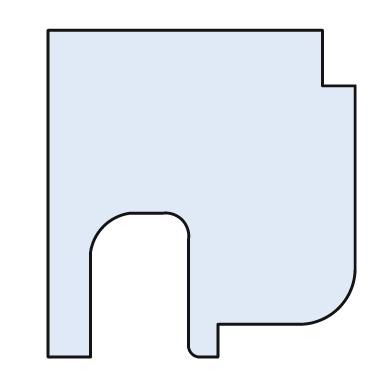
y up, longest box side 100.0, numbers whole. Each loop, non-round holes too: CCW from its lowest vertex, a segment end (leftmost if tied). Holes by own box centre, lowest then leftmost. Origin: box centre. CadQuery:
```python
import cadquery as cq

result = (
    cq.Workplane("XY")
    .moveTo(-47.0, -50.0)
    .lineTo(-34.0, -50.0)
    .lineTo(-34.0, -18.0)
    .threePointArc((-30.0, -10.0), (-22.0, -6.0))
    .lineTo(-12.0, -6.0)
    .threePointArc((-6.0, -8.0), (-4.0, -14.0))
    .lineTo(-4.0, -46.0)
    .threePointArc((-3.0, -49.0), (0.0, -50.0))
    .lineTo(5.0, -50.0)
    .lineTo(5.0, -40.0)
    .lineTo(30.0, -40.0)
    .threePointArc((42.0, -35.0), (47.0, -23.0))
    .lineTo(47.0, 33.0)
    .lineTo(37.0, 33.0)
    .lineTo(37.0, 50.0)
    .lineTo(-47.0, 50.0)
    .close()
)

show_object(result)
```